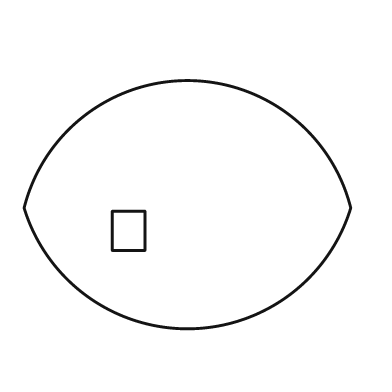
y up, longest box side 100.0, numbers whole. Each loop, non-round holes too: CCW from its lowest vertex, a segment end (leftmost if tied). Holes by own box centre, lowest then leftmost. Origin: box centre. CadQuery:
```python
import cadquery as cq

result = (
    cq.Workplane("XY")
    .moveTo(-50.0, -1.0)
    .threePointArc((0.0, -38.0), (50.0, -1.0))
    .threePointArc((0.0, 38.0), (-50.0, -1.0))
    .close()
    .moveTo(-23.0, -14.0)
    .lineTo(-13.0, -14.0)
    .lineTo(-13.0, -2.0)
    .lineTo(-23.0, -2.0)
    .close()
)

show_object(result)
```